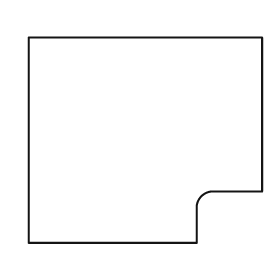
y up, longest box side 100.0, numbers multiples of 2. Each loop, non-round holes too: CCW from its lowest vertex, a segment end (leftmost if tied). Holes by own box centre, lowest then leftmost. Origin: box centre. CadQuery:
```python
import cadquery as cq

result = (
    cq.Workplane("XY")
    .moveTo(-50.0, -44.0)
    .lineTo(22.0, -44.0)
    .lineTo(22.0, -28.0)
    .threePointArc((24.0, -24.0), (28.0, -22.0))
    .lineTo(50.0, -22.0)
    .lineTo(50.0, 44.0)
    .lineTo(-50.0, 44.0)
    .close()
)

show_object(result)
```